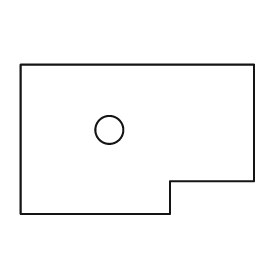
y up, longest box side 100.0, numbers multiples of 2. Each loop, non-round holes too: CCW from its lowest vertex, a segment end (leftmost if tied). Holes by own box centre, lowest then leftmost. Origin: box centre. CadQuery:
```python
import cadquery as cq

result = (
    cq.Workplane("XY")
    .moveTo(-50.0, -32.0)
    .lineTo(14.0, -32.0)
    .lineTo(14.0, -18.0)
    .lineTo(50.0, -18.0)
    .lineTo(50.0, 32.0)
    .lineTo(-50.0, 32.0)
    .close()
    .moveTo(-12.0, 4.0)
    .circle(6.0)
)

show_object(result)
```